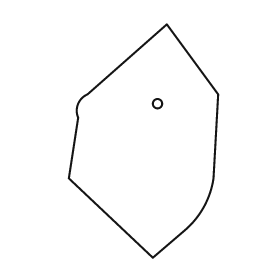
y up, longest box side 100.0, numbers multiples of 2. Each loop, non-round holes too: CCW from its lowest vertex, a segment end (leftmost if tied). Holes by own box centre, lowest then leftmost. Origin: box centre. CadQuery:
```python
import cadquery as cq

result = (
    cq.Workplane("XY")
    .moveTo(4.0, -50.0)
    .lineTo(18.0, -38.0)
    .threePointArc((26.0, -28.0), (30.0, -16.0))
    .lineTo(32.0, 20.0)
    .lineTo(10.0, 50.0)
    .lineTo(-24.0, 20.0)
    .threePointArc((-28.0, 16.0), (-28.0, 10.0))
    .lineTo(-32.0, -16.0)
    .close()
    .moveTo(6.0, 16.0)
    .circle(2.0)
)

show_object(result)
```